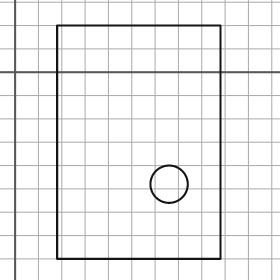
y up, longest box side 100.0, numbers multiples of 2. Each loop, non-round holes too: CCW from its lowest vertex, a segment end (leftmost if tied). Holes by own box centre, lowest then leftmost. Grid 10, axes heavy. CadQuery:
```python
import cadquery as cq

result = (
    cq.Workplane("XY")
    .moveTo(18.0, -80.0)
    .lineTo(88.0, -80.0)
    .lineTo(88.0, 20.0)
    .lineTo(18.0, 20.0)
    .close()
    .moveTo(66.0, -48.0)
    .circle(8.0)
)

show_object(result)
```